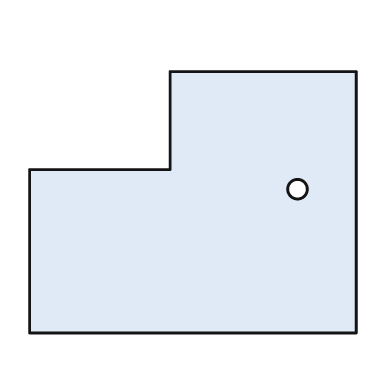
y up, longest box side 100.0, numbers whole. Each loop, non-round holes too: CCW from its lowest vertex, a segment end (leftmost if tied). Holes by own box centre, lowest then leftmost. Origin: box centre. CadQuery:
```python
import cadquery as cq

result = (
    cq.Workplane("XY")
    .moveTo(-50.0, -40.0)
    .lineTo(50.0, -40.0)
    .lineTo(50.0, 40.0)
    .lineTo(-7.0, 40.0)
    .lineTo(-7.0, 10.0)
    .lineTo(-50.0, 10.0)
    .close()
    .moveTo(32.0, 4.0)
    .circle(3.0)
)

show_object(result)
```